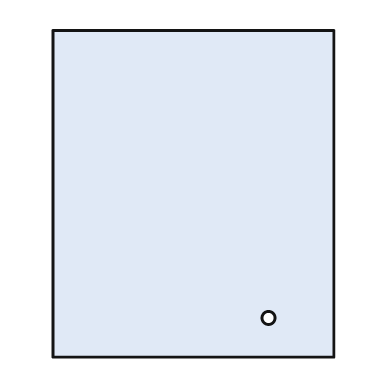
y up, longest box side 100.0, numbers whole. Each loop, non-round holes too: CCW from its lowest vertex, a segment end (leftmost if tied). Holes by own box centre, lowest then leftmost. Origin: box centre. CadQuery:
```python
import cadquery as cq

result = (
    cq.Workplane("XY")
    .moveTo(-43.0, -50.0)
    .lineTo(43.0, -50.0)
    .lineTo(43.0, 50.0)
    .lineTo(-43.0, 50.0)
    .close()
    .moveTo(23.0, -38.0)
    .circle(2.0)
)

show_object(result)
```